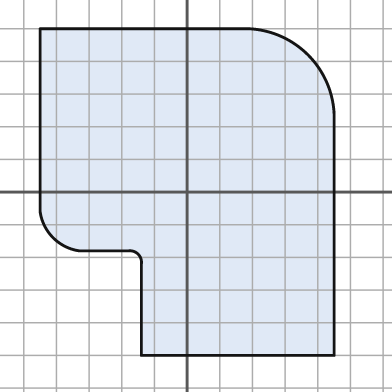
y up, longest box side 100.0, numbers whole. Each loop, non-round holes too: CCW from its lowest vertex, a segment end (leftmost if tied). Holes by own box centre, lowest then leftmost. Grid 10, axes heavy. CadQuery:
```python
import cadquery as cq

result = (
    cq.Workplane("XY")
    .moveTo(-14.0, -50.0)
    .lineTo(45.0, -50.0)
    .lineTo(45.0, 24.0)
    .threePointArc((37.0, 42.0), (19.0, 50.0))
    .lineTo(-45.0, 50.0)
    .lineTo(-45.0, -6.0)
    .threePointArc((-41.0, -14.0), (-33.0, -18.0))
    .lineTo(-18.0, -18.0)
    .threePointArc((-15.0, -19.0), (-14.0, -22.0))
    .close()
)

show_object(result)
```